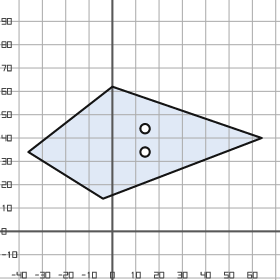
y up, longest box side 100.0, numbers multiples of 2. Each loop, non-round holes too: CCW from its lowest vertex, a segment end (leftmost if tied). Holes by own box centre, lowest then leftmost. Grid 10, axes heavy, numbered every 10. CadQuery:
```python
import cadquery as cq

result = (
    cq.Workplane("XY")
    .moveTo(-4.0, 14.0)
    .lineTo(64.0, 40.0)
    .lineTo(0.0, 62.0)
    .lineTo(-36.0, 34.0)
    .close()
    .moveTo(14.0, 34.0)
    .circle(2.0)
    .moveTo(14.0, 44.0)
    .circle(2.0)
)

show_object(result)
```